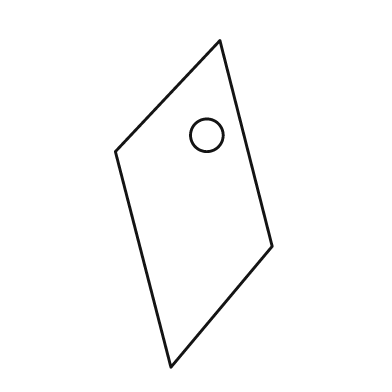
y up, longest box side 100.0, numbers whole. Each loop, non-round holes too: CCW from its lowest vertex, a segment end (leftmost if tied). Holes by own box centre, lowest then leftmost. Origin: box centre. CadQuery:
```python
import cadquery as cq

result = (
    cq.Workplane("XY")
    .moveTo(-7.0, -50.0)
    .lineTo(24.0, -13.0)
    .lineTo(8.0, 50.0)
    .lineTo(-24.0, 16.0)
    .close()
    .moveTo(4.0, 21.0)
    .circle(5.0)
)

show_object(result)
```